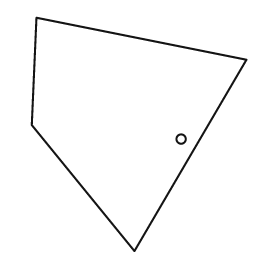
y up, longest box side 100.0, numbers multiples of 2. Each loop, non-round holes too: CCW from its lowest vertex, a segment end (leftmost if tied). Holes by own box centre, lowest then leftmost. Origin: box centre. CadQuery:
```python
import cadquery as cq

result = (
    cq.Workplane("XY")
    .moveTo(-2.0, -50.0)
    .lineTo(46.0, 32.0)
    .lineTo(-44.0, 50.0)
    .lineTo(-46.0, 4.0)
    .close()
    .moveTo(18.0, -2.0)
    .circle(2.0)
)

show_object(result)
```